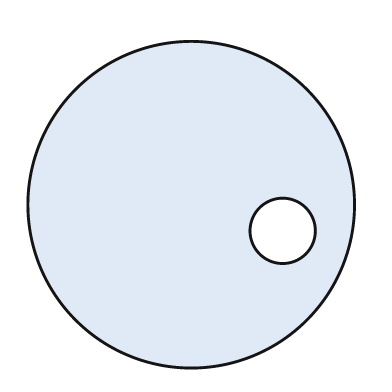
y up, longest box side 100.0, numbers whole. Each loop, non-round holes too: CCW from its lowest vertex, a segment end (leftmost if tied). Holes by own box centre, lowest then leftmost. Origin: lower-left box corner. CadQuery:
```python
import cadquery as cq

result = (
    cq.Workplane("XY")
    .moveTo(50.0, 50.0)
    .circle(50.0)
    .moveTo(78.0, 42.0)
    .circle(10.0)
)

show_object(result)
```